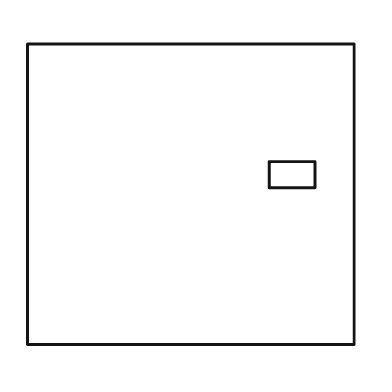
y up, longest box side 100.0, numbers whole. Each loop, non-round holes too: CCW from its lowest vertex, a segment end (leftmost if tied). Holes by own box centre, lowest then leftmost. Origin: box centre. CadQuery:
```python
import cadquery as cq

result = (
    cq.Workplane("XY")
    .moveTo(-50.0, -46.0)
    .lineTo(50.0, -46.0)
    .lineTo(50.0, 46.0)
    .lineTo(-50.0, 46.0)
    .close()
    .moveTo(24.0, 2.0)
    .lineTo(38.0, 2.0)
    .lineTo(38.0, 10.0)
    .lineTo(24.0, 10.0)
    .close()
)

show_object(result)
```